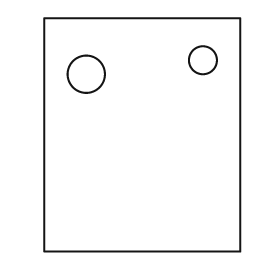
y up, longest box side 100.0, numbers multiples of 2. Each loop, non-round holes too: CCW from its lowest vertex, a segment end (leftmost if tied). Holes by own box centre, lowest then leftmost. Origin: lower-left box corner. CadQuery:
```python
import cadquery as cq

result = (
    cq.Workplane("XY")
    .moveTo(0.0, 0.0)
    .lineTo(84.0, 0.0)
    .lineTo(84.0, 100.0)
    .lineTo(0.0, 100.0)
    .close()
    .moveTo(18.0, 76.0)
    .circle(8.0)
    .moveTo(68.0, 82.0)
    .circle(6.0)
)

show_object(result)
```